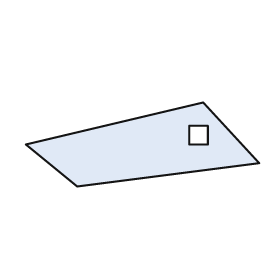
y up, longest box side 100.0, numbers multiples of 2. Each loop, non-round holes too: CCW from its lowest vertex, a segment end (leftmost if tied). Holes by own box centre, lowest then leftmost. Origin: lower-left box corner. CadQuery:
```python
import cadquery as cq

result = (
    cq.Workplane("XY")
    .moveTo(22.0, 0.0)
    .lineTo(100.0, 10.0)
    .lineTo(76.0, 36.0)
    .lineTo(0.0, 18.0)
    .close()
    .moveTo(70.0, 18.0)
    .lineTo(78.0, 18.0)
    .lineTo(78.0, 26.0)
    .lineTo(70.0, 26.0)
    .close()
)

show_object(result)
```